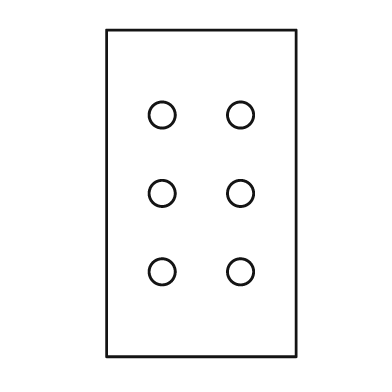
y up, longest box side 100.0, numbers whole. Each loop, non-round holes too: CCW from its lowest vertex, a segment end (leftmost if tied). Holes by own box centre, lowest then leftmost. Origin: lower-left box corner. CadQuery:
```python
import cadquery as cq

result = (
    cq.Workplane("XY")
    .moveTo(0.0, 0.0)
    .lineTo(58.0, 0.0)
    .lineTo(58.0, 100.0)
    .lineTo(0.0, 100.0)
    .close()
    .moveTo(17.0, 26.0)
    .circle(4.0)
    .moveTo(41.0, 26.0)
    .circle(4.0)
    .moveTo(17.0, 50.0)
    .circle(4.0)
    .moveTo(41.0, 50.0)
    .circle(4.0)
    .moveTo(17.0, 74.0)
    .circle(4.0)
    .moveTo(41.0, 74.0)
    .circle(4.0)
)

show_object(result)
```